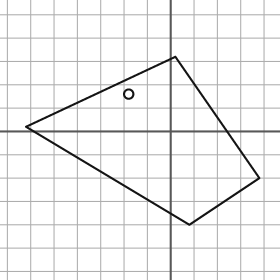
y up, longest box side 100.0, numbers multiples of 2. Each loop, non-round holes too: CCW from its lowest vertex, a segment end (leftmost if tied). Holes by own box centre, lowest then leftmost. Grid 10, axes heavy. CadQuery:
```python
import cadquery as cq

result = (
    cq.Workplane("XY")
    .moveTo(8.0, -40.0)
    .lineTo(38.0, -20.0)
    .lineTo(2.0, 32.0)
    .lineTo(-62.0, 2.0)
    .close()
    .moveTo(-18.0, 16.0)
    .circle(2.0)
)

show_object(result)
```